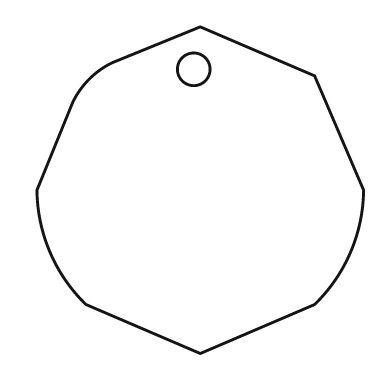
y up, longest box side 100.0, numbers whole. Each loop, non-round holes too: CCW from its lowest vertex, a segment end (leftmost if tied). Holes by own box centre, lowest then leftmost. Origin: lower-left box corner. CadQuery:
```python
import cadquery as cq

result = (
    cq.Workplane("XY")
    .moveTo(50.0, 0.0)
    .lineTo(85.0, 15.0)
    .threePointArc((96.0, 31.0), (100.0, 50.0))
    .lineTo(85.0, 85.0)
    .lineTo(50.0, 100.0)
    .lineTo(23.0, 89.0)
    .threePointArc((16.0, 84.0), (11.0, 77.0))
    .lineTo(0.0, 50.0)
    .threePointArc((4.0, 31.0), (15.0, 15.0))
    .close()
    .moveTo(48.0, 87.0)
    .circle(5.0)
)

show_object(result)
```